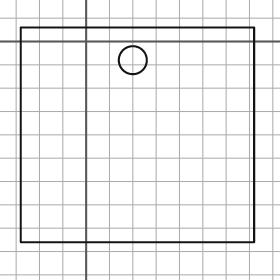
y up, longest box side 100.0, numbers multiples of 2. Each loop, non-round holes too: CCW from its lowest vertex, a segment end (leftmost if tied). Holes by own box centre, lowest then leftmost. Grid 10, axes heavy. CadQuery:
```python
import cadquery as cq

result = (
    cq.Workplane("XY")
    .moveTo(-28.0, -86.0)
    .lineTo(72.0, -86.0)
    .lineTo(72.0, 6.0)
    .lineTo(-28.0, 6.0)
    .close()
    .moveTo(20.0, -8.0)
    .circle(6.0)
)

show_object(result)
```